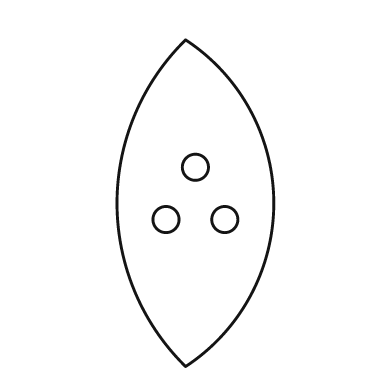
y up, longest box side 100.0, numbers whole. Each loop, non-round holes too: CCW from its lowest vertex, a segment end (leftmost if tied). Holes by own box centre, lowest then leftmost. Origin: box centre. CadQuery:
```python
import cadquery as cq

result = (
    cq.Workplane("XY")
    .moveTo(-3.0, -50.0)
    .threePointArc((24.0, 0.0), (-3.0, 50.0))
    .threePointArc((-24.0, 0.0), (-3.0, -50.0))
    .close()
    .moveTo(-9.0, -5.0)
    .circle(4.0)
    .moveTo(9.0, -5.0)
    .circle(4.0)
    .moveTo(0.0, 11.0)
    .circle(4.0)
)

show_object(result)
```